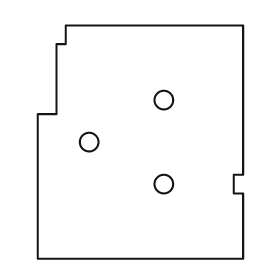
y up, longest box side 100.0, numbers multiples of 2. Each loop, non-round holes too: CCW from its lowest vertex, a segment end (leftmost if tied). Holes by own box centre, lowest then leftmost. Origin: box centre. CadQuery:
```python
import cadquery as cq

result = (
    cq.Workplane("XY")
    .moveTo(-44.0, -50.0)
    .lineTo(44.0, -50.0)
    .lineTo(44.0, -22.0)
    .lineTo(40.0, -22.0)
    .lineTo(40.0, -14.0)
    .lineTo(44.0, -14.0)
    .lineTo(44.0, 50.0)
    .lineTo(-32.0, 50.0)
    .lineTo(-32.0, 42.0)
    .lineTo(-36.0, 42.0)
    .lineTo(-36.0, 12.0)
    .lineTo(-44.0, 12.0)
    .close()
    .moveTo(10.0, -18.0)
    .circle(4.0)
    .moveTo(-22.0, 0.0)
    .circle(4.0)
    .moveTo(10.0, 18.0)
    .circle(4.0)
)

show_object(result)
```